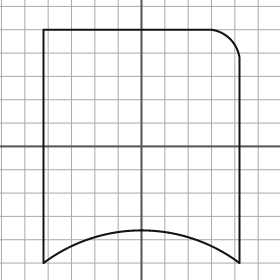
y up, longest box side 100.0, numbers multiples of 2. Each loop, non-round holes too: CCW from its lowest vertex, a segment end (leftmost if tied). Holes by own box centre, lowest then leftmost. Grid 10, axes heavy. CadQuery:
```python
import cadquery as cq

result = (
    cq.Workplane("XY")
    .moveTo(-42.0, -50.0)
    .threePointArc((0.0, -36.0), (42.0, -50.0))
    .lineTo(42.0, 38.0)
    .threePointArc((38.0, 46.0), (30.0, 50.0))
    .lineTo(-42.0, 50.0)
    .close()
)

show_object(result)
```